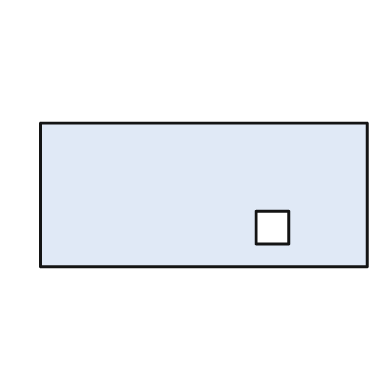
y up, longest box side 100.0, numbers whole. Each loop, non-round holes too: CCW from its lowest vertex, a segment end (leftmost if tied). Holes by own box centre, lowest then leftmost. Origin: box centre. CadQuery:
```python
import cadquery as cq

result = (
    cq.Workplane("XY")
    .moveTo(-50.0, -22.0)
    .lineTo(50.0, -22.0)
    .lineTo(50.0, 22.0)
    .lineTo(-50.0, 22.0)
    .close()
    .moveTo(16.0, -15.0)
    .lineTo(26.0, -15.0)
    .lineTo(26.0, -5.0)
    .lineTo(16.0, -5.0)
    .close()
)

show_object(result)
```